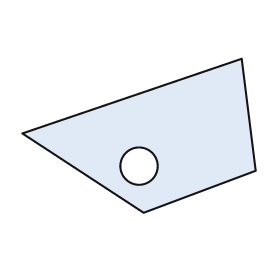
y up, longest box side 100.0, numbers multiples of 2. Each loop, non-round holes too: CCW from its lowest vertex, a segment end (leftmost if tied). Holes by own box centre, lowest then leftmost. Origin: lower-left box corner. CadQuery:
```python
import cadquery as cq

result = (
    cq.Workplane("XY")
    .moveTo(52.0, 0.0)
    .lineTo(100.0, 18.0)
    .lineTo(94.0, 66.0)
    .lineTo(0.0, 34.0)
    .close()
    .moveTo(50.0, 20.0)
    .circle(8.0)
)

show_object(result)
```